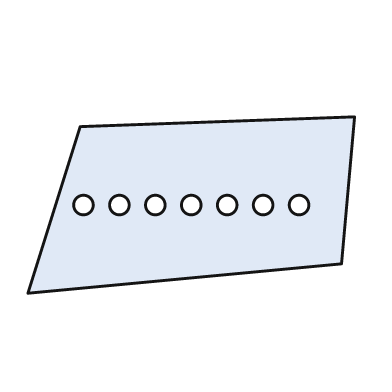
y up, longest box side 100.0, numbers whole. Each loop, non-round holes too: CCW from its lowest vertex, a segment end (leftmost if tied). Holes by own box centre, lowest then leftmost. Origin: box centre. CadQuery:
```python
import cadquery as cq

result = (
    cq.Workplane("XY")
    .moveTo(-50.0, -27.0)
    .lineTo(46.0, -18.0)
    .lineTo(50.0, 27.0)
    .lineTo(-34.0, 24.0)
    .close()
    .moveTo(-33.0, 0.0)
    .circle(3.0)
    .moveTo(-22.0, 0.0)
    .circle(3.0)
    .moveTo(-11.0, 0.0)
    .circle(3.0)
    .moveTo(0.0, 0.0)
    .circle(3.0)
    .moveTo(11.0, 0.0)
    .circle(3.0)
    .moveTo(22.0, 0.0)
    .circle(3.0)
    .moveTo(33.0, 0.0)
    .circle(3.0)
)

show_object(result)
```